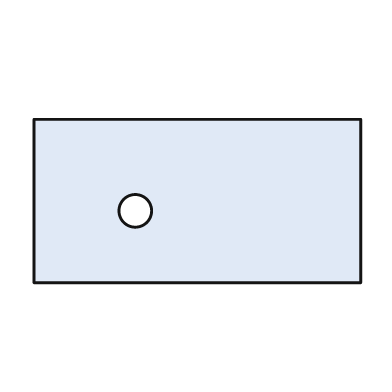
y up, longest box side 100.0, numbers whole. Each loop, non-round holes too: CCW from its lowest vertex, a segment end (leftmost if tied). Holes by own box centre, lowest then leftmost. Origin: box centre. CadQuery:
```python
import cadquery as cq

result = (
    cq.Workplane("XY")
    .moveTo(-50.0, -25.0)
    .lineTo(50.0, -25.0)
    .lineTo(50.0, 25.0)
    .lineTo(-50.0, 25.0)
    .close()
    .moveTo(-19.0, -3.0)
    .circle(5.0)
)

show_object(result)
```